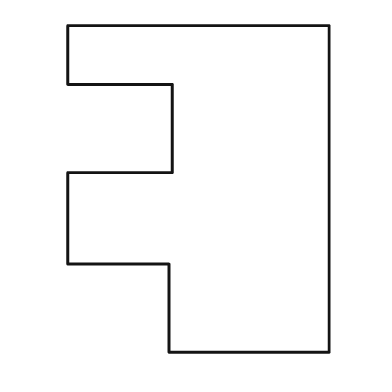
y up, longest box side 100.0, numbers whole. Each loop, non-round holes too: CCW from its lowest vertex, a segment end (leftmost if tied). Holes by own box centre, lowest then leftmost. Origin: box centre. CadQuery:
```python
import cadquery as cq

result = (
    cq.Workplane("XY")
    .moveTo(-9.0, -50.0)
    .lineTo(40.0, -50.0)
    .lineTo(40.0, 50.0)
    .lineTo(-40.0, 50.0)
    .lineTo(-40.0, 32.0)
    .lineTo(-8.0, 32.0)
    .lineTo(-8.0, 5.0)
    .lineTo(-40.0, 5.0)
    .lineTo(-40.0, -23.0)
    .lineTo(-9.0, -23.0)
    .close()
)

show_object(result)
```